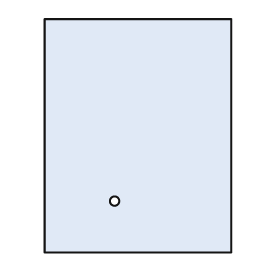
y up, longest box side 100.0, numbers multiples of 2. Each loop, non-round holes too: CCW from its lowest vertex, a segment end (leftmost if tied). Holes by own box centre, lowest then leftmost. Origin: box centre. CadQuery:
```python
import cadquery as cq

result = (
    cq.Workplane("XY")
    .moveTo(-40.0, -50.0)
    .lineTo(40.0, -50.0)
    .lineTo(40.0, 50.0)
    .lineTo(-40.0, 50.0)
    .close()
    .moveTo(-10.0, -28.0)
    .circle(2.0)
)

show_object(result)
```